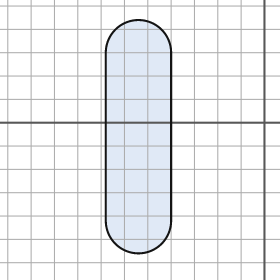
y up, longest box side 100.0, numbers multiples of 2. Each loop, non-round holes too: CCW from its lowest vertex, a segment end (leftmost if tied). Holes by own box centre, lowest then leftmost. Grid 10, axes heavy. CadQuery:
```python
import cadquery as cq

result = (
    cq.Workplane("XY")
    .moveTo(-68.0, -42.0)
    .threePointArc((-54.0, -56.0), (-40.0, -42.0))
    .lineTo(-40.0, 30.0)
    .threePointArc((-54.0, 44.0), (-68.0, 30.0))
    .close()
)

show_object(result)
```